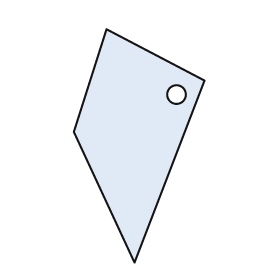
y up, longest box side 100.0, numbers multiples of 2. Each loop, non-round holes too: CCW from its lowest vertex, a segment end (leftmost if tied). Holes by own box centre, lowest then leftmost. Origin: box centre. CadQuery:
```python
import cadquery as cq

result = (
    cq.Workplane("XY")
    .moveTo(-2.0, -50.0)
    .lineTo(28.0, 28.0)
    .lineTo(-14.0, 50.0)
    .lineTo(-28.0, 6.0)
    .close()
    .moveTo(16.0, 22.0)
    .circle(4.0)
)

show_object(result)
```